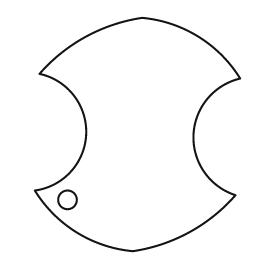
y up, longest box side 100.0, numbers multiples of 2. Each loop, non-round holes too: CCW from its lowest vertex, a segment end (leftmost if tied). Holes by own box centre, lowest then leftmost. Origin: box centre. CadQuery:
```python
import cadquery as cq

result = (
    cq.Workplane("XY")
    .moveTo(-2.0, -50.0)
    .threePointArc((22.0, -42.0), (42.0, -26.0))
    .threePointArc((24.0, 0.0), (44.0, 24.0))
    .threePointArc((26.0, 42.0), (2.0, 50.0))
    .threePointArc((-22.0, 42.0), (-42.0, 26.0))
    .threePointArc((-22.0, 0.0), (-44.0, -24.0))
    .threePointArc((-26.0, -42.0), (-2.0, -50.0))
    .close()
    .moveTo(-30.0, -28.0)
    .circle(4.0)
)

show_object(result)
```